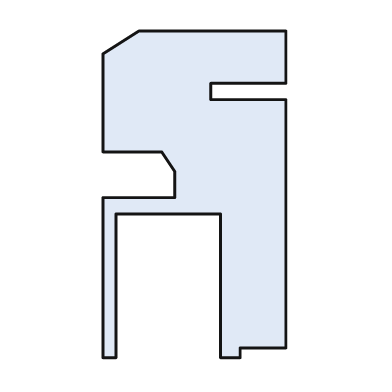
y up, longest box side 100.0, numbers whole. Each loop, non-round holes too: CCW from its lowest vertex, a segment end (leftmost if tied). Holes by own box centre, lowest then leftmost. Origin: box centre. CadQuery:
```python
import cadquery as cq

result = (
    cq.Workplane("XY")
    .moveTo(-28.0, -50.0)
    .lineTo(-24.0, -50.0)
    .lineTo(-24.0, -6.0)
    .lineTo(8.0, -6.0)
    .lineTo(8.0, -50.0)
    .lineTo(14.0, -50.0)
    .lineTo(14.0, -47.0)
    .lineTo(28.0, -47.0)
    .lineTo(28.0, 29.0)
    .lineTo(5.0, 29.0)
    .lineTo(5.0, 34.0)
    .lineTo(28.0, 34.0)
    .lineTo(28.0, 50.0)
    .lineTo(-17.0, 50.0)
    .lineTo(-28.0, 43.0)
    .lineTo(-28.0, 13.0)
    .lineTo(-10.0, 13.0)
    .lineTo(-6.0, 7.0)
    .lineTo(-6.0, -1.0)
    .lineTo(-28.0, -1.0)
    .close()
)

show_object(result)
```